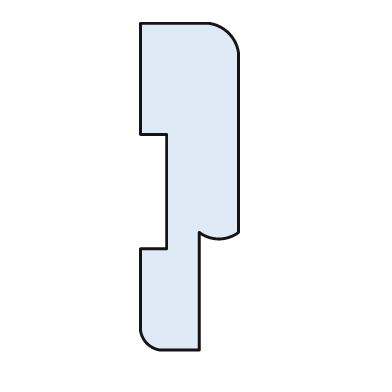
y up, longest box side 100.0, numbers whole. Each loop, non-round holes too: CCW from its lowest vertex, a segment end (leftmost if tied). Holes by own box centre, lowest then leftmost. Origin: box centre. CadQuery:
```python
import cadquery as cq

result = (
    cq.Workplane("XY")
    .moveTo(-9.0, -50.0)
    .lineTo(3.0, -50.0)
    .lineTo(3.0, -14.0)
    .threePointArc((9.0, -16.0), (15.0, -14.0))
    .lineTo(15.0, 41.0)
    .threePointArc((12.0, 47.0), (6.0, 50.0))
    .lineTo(-15.0, 50.0)
    .lineTo(-15.0, 16.0)
    .lineTo(-7.0, 16.0)
    .lineTo(-7.0, -19.0)
    .lineTo(-15.0, -19.0)
    .lineTo(-15.0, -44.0)
    .threePointArc((-13.0, -48.0), (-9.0, -50.0))
    .close()
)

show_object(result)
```